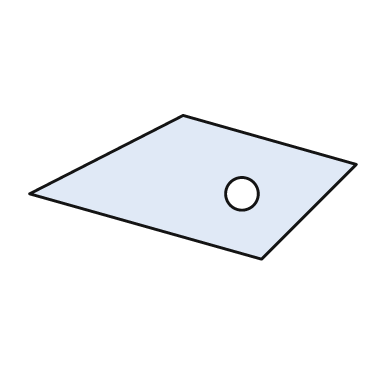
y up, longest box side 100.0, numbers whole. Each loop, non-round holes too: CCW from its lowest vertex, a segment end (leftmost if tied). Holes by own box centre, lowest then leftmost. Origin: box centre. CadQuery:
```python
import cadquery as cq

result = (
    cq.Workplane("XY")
    .moveTo(21.0, -22.0)
    .lineTo(50.0, 7.0)
    .lineTo(-3.0, 22.0)
    .lineTo(-50.0, -2.0)
    .close()
    .moveTo(15.0, -2.0)
    .circle(5.0)
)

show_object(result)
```